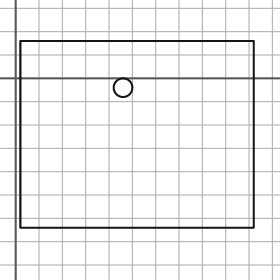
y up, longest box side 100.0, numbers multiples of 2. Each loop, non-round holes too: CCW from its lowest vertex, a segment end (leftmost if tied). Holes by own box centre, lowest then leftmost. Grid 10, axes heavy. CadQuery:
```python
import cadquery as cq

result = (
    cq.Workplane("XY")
    .moveTo(2.0, -64.0)
    .lineTo(102.0, -64.0)
    .lineTo(102.0, 16.0)
    .lineTo(2.0, 16.0)
    .close()
    .moveTo(46.0, -4.0)
    .circle(4.0)
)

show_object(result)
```